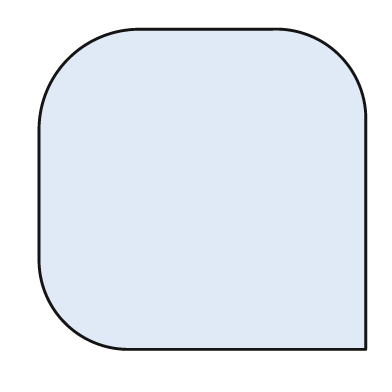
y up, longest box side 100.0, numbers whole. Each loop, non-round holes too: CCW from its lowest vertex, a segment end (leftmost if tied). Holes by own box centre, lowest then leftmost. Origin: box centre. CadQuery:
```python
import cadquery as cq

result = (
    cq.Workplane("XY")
    .moveTo(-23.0, -49.0)
    .lineTo(50.0, -49.0)
    .lineTo(50.0, 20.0)
    .threePointArc((42.0, 41.0), (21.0, 49.0))
    .lineTo(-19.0, 49.0)
    .threePointArc((-41.0, 40.0), (-50.0, 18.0))
    .lineTo(-50.0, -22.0)
    .threePointArc((-42.0, -41.0), (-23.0, -49.0))
    .close()
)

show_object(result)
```